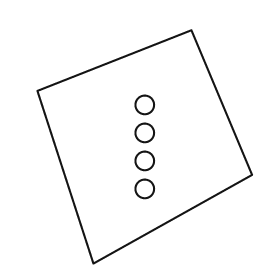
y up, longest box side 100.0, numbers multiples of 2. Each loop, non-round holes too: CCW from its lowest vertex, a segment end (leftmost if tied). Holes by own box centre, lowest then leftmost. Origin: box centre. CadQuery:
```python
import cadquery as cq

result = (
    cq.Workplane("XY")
    .moveTo(-22.0, -50.0)
    .lineTo(46.0, -12.0)
    .lineTo(20.0, 50.0)
    .lineTo(-46.0, 24.0)
    .close()
    .moveTo(0.0, -18.0)
    .circle(4.0)
    .moveTo(0.0, -6.0)
    .circle(4.0)
    .moveTo(0.0, 6.0)
    .circle(4.0)
    .moveTo(0.0, 18.0)
    .circle(4.0)
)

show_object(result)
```